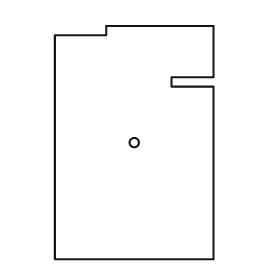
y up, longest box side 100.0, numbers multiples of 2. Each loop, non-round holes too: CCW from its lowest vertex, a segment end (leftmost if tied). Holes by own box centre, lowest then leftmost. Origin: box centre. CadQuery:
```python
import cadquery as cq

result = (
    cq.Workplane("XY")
    .moveTo(-34.0, -50.0)
    .lineTo(34.0, -50.0)
    .lineTo(34.0, 24.0)
    .lineTo(16.0, 24.0)
    .lineTo(16.0, 28.0)
    .lineTo(34.0, 28.0)
    .lineTo(34.0, 50.0)
    .lineTo(-12.0, 50.0)
    .lineTo(-12.0, 46.0)
    .lineTo(-34.0, 46.0)
    .close()
    .moveTo(0.0, 0.0)
    .circle(2.0)
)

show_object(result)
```